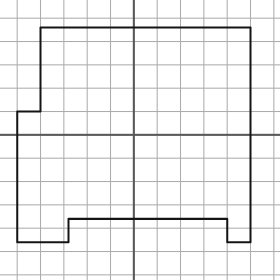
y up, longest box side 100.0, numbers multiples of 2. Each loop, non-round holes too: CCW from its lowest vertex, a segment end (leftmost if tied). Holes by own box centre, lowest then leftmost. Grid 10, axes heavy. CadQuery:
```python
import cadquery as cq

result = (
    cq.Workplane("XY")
    .moveTo(-50.0, -46.0)
    .lineTo(-28.0, -46.0)
    .lineTo(-28.0, -36.0)
    .lineTo(40.0, -36.0)
    .lineTo(40.0, -46.0)
    .lineTo(50.0, -46.0)
    .lineTo(50.0, 46.0)
    .lineTo(-40.0, 46.0)
    .lineTo(-40.0, 10.0)
    .lineTo(-50.0, 10.0)
    .close()
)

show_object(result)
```